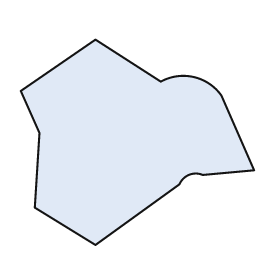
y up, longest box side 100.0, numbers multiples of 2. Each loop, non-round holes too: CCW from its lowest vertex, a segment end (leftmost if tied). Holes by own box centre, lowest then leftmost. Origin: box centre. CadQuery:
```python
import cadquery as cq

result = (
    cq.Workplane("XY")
    .moveTo(-18.0, -44.0)
    .lineTo(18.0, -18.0)
    .threePointArc((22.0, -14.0), (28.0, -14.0))
    .lineTo(50.0, -12.0)
    .lineTo(36.0, 20.0)
    .threePointArc((24.0, 28.0), (10.0, 26.0))
    .lineTo(-18.0, 44.0)
    .lineTo(-50.0, 22.0)
    .lineTo(-42.0, 4.0)
    .lineTo(-44.0, -28.0)
    .close()
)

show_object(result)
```